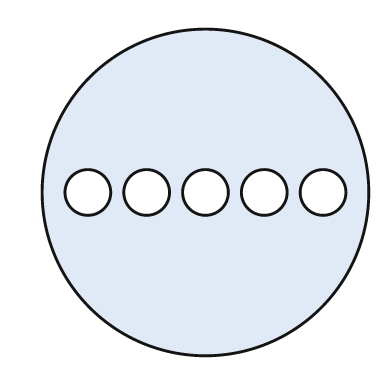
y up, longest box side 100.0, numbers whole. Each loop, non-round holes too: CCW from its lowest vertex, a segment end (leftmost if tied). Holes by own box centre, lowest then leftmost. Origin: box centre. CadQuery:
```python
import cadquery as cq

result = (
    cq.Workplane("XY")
    .moveTo(0.0, 0.0)
    .circle(50.0)
    .moveTo(-36.0, 0.0)
    .circle(7.0)
    .moveTo(-18.0, 0.0)
    .circle(7.0)
    .moveTo(0.0, 0.0)
    .circle(7.0)
    .moveTo(18.0, 0.0)
    .circle(7.0)
    .moveTo(36.0, 0.0)
    .circle(7.0)
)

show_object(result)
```